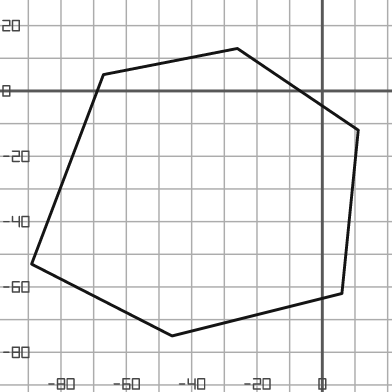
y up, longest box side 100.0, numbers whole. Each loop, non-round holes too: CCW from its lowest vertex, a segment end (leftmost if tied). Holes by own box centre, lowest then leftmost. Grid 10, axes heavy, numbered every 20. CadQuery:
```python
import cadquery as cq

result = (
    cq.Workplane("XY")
    .moveTo(-46.0, -75.0)
    .lineTo(6.0, -62.0)
    .lineTo(11.0, -12.0)
    .lineTo(-26.0, 13.0)
    .lineTo(-67.0, 5.0)
    .lineTo(-89.0, -53.0)
    .close()
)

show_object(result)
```